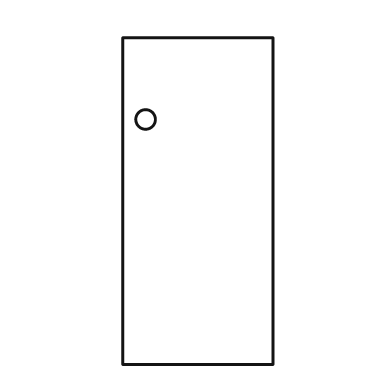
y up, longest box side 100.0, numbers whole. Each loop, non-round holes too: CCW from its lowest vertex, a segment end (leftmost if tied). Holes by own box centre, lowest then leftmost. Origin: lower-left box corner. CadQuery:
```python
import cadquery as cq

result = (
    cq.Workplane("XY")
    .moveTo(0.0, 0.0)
    .lineTo(46.0, 0.0)
    .lineTo(46.0, 100.0)
    .lineTo(0.0, 100.0)
    .close()
    .moveTo(7.0, 75.0)
    .circle(3.0)
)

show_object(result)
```